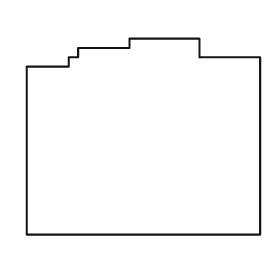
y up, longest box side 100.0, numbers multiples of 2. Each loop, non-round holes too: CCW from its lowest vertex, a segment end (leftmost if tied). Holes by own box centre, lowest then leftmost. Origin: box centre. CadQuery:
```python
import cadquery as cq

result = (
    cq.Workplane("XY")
    .moveTo(-50.0, -42.0)
    .lineTo(50.0, -42.0)
    .lineTo(50.0, 34.0)
    .lineTo(24.0, 34.0)
    .lineTo(24.0, 42.0)
    .lineTo(-6.0, 42.0)
    .lineTo(-6.0, 38.0)
    .lineTo(-28.0, 38.0)
    .lineTo(-28.0, 34.0)
    .lineTo(-32.0, 34.0)
    .lineTo(-32.0, 30.0)
    .lineTo(-50.0, 30.0)
    .close()
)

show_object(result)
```